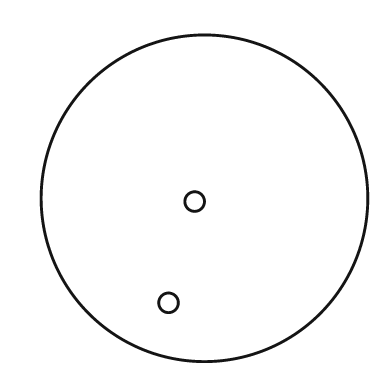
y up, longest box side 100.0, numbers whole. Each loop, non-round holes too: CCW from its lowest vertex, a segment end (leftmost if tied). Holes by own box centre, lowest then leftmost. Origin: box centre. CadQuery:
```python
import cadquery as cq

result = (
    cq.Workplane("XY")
    .moveTo(0.0, 0.0)
    .circle(50.0)
    .moveTo(-11.0, -32.0)
    .circle(3.0)
    .moveTo(-3.0, -1.0)
    .circle(3.0)
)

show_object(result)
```